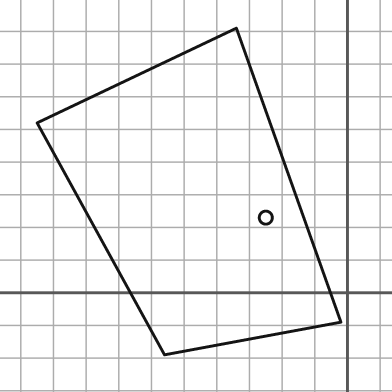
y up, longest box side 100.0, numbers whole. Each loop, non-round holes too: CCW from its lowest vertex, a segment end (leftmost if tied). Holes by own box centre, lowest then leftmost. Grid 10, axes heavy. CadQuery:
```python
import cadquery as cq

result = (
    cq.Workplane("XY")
    .moveTo(-56.0, -19.0)
    .lineTo(-2.0, -9.0)
    .lineTo(-34.0, 81.0)
    .lineTo(-95.0, 52.0)
    .close()
    .moveTo(-25.0, 23.0)
    .circle(2.0)
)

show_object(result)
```